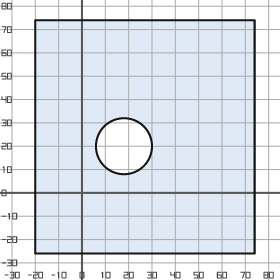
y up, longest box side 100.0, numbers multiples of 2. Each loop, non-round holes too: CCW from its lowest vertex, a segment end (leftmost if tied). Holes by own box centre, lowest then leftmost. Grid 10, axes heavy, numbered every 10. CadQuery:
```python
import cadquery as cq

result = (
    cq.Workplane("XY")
    .moveTo(-20.0, -26.0)
    .lineTo(74.0, -26.0)
    .lineTo(74.0, 74.0)
    .lineTo(-20.0, 74.0)
    .close()
    .moveTo(18.0, 20.0)
    .circle(12.0)
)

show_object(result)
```